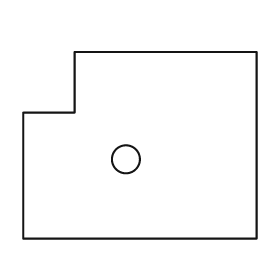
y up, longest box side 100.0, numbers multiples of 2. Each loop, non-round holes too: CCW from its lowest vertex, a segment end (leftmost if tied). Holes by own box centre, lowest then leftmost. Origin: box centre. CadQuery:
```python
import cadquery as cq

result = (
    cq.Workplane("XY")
    .moveTo(-50.0, -40.0)
    .lineTo(50.0, -40.0)
    .lineTo(50.0, 40.0)
    .lineTo(-28.0, 40.0)
    .lineTo(-28.0, 14.0)
    .lineTo(-50.0, 14.0)
    .close()
    .moveTo(-6.0, -6.0)
    .circle(6.0)
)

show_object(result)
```